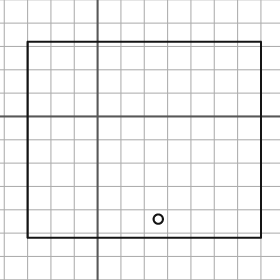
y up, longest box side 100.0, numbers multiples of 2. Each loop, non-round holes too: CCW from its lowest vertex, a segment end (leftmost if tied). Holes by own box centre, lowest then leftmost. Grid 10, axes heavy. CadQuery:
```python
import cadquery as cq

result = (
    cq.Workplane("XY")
    .moveTo(-30.0, -52.0)
    .lineTo(70.0, -52.0)
    .lineTo(70.0, 32.0)
    .lineTo(-30.0, 32.0)
    .close()
    .moveTo(26.0, -44.0)
    .circle(2.0)
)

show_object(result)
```